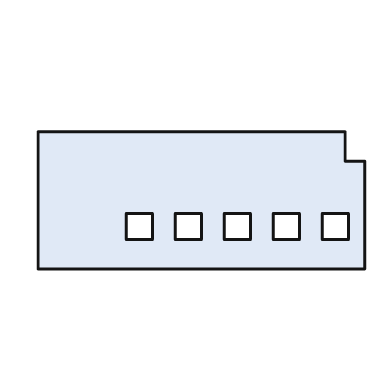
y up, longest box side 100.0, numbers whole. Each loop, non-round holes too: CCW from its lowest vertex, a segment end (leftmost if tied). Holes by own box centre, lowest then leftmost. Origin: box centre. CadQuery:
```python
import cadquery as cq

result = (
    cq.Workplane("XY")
    .moveTo(-50.0, -21.0)
    .lineTo(50.0, -21.0)
    .lineTo(50.0, 12.0)
    .lineTo(44.0, 12.0)
    .lineTo(44.0, 21.0)
    .lineTo(-50.0, 21.0)
    .close()
    .moveTo(-23.0, -12.0)
    .lineTo(-15.0, -12.0)
    .lineTo(-15.0, -4.0)
    .lineTo(-23.0, -4.0)
    .close()
    .moveTo(-8.0, -12.0)
    .lineTo(0.0, -12.0)
    .lineTo(0.0, -4.0)
    .lineTo(-8.0, -4.0)
    .close()
    .moveTo(7.0, -12.0)
    .lineTo(15.0, -12.0)
    .lineTo(15.0, -4.0)
    .lineTo(7.0, -4.0)
    .close()
    .moveTo(22.0, -12.0)
    .lineTo(30.0, -12.0)
    .lineTo(30.0, -4.0)
    .lineTo(22.0, -4.0)
    .close()
    .moveTo(37.0, -12.0)
    .lineTo(45.0, -12.0)
    .lineTo(45.0, -4.0)
    .lineTo(37.0, -4.0)
    .close()
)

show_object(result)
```